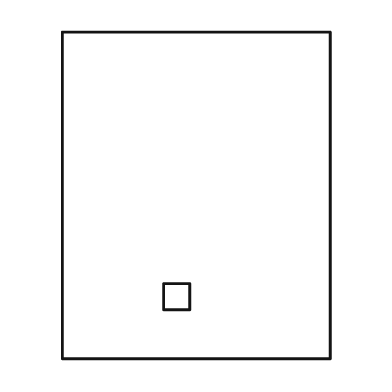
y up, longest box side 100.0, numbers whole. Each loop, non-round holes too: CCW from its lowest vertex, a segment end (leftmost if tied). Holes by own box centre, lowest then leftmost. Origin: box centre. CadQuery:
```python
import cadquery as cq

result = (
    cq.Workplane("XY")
    .moveTo(-41.0, -50.0)
    .lineTo(41.0, -50.0)
    .lineTo(41.0, 50.0)
    .lineTo(-41.0, 50.0)
    .close()
    .moveTo(-10.0, -35.0)
    .lineTo(-2.0, -35.0)
    .lineTo(-2.0, -27.0)
    .lineTo(-10.0, -27.0)
    .close()
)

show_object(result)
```